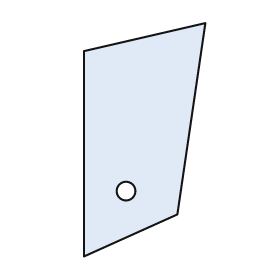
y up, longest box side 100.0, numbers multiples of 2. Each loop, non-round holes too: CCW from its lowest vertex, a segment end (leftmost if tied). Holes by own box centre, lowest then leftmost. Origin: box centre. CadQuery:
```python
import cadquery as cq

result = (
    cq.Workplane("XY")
    .moveTo(-26.0, -50.0)
    .lineTo(14.0, -32.0)
    .lineTo(26.0, 50.0)
    .lineTo(-26.0, 38.0)
    .close()
    .moveTo(-8.0, -22.0)
    .circle(4.0)
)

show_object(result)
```